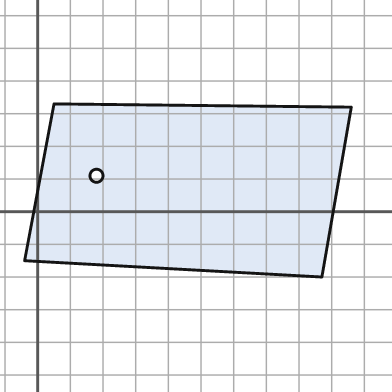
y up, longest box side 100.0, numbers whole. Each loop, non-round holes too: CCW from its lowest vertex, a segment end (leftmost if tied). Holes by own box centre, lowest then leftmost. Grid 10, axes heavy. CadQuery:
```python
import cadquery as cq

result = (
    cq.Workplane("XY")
    .moveTo(87.0, -20.0)
    .lineTo(96.0, 32.0)
    .lineTo(5.0, 33.0)
    .lineTo(-4.0, -15.0)
    .close()
    .moveTo(18.0, 11.0)
    .circle(2.0)
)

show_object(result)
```